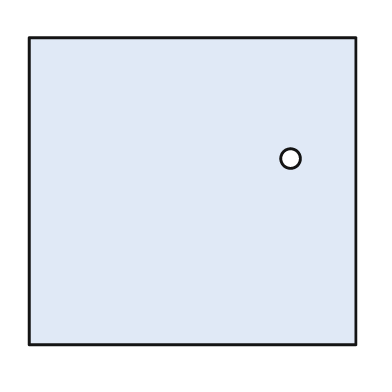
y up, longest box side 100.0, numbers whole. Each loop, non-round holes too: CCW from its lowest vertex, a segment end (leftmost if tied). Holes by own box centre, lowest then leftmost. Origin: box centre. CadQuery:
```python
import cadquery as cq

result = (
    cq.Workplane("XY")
    .moveTo(-50.0, -47.0)
    .lineTo(50.0, -47.0)
    .lineTo(50.0, 47.0)
    .lineTo(-50.0, 47.0)
    .close()
    .moveTo(30.0, 10.0)
    .circle(3.0)
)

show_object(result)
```